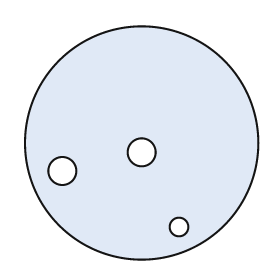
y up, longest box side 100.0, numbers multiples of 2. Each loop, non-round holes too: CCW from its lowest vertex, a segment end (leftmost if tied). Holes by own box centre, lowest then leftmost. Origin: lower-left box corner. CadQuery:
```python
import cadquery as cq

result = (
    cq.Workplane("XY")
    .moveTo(50.0, 50.0)
    .circle(50.0)
    .moveTo(66.0, 14.0)
    .circle(4.0)
    .moveTo(16.0, 38.0)
    .circle(6.0)
    .moveTo(50.0, 46.0)
    .circle(6.0)
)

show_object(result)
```